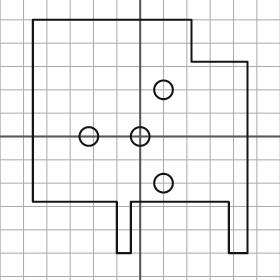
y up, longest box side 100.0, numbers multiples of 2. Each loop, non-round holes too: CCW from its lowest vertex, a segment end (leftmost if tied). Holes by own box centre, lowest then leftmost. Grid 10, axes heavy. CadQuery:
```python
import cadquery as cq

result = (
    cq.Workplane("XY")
    .moveTo(-10.0, -50.0)
    .lineTo(-4.0, -50.0)
    .lineTo(-4.0, -28.0)
    .lineTo(38.0, -28.0)
    .lineTo(38.0, -50.0)
    .lineTo(46.0, -50.0)
    .lineTo(46.0, 32.0)
    .lineTo(22.0, 32.0)
    .lineTo(22.0, 50.0)
    .lineTo(-46.0, 50.0)
    .lineTo(-46.0, -28.0)
    .lineTo(-10.0, -28.0)
    .close()
    .moveTo(10.0, -20.0)
    .circle(4.0)
    .moveTo(-22.0, 0.0)
    .circle(4.0)
    .moveTo(0.0, 0.0)
    .circle(4.0)
    .moveTo(10.0, 20.0)
    .circle(4.0)
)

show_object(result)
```